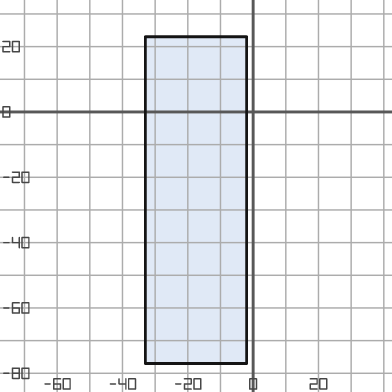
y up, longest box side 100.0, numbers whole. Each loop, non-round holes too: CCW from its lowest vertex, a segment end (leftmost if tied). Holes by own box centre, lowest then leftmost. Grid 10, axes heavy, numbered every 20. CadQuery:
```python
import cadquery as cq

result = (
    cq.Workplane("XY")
    .moveTo(-33.0, -77.0)
    .lineTo(-2.0, -77.0)
    .lineTo(-2.0, 23.0)
    .lineTo(-33.0, 23.0)
    .close()
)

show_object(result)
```